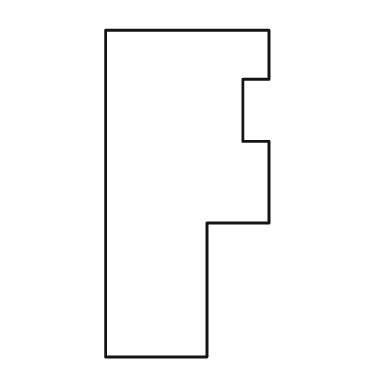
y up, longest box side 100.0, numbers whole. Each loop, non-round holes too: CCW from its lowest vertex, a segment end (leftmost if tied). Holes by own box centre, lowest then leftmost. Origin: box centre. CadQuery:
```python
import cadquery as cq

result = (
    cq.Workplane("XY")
    .moveTo(-25.0, -50.0)
    .lineTo(6.0, -50.0)
    .lineTo(6.0, -9.0)
    .lineTo(25.0, -9.0)
    .lineTo(25.0, 16.0)
    .lineTo(17.0, 16.0)
    .lineTo(17.0, 35.0)
    .lineTo(25.0, 35.0)
    .lineTo(25.0, 50.0)
    .lineTo(-25.0, 50.0)
    .close()
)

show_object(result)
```